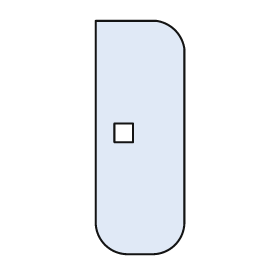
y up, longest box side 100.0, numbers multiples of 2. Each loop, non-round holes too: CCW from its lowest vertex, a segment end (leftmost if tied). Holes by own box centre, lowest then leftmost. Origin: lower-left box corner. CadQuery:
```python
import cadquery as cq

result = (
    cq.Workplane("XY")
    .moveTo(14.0, 0.0)
    .lineTo(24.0, 0.0)
    .threePointArc((34.0, 4.0), (38.0, 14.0))
    .lineTo(38.0, 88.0)
    .threePointArc((34.0, 96.0), (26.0, 100.0))
    .lineTo(0.0, 100.0)
    .lineTo(0.0, 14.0)
    .threePointArc((4.0, 4.0), (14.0, 0.0))
    .close()
    .moveTo(8.0, 48.0)
    .lineTo(16.0, 48.0)
    .lineTo(16.0, 56.0)
    .lineTo(8.0, 56.0)
    .close()
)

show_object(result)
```